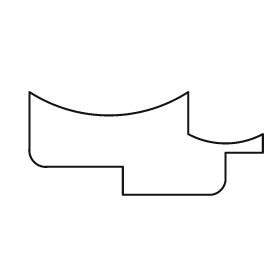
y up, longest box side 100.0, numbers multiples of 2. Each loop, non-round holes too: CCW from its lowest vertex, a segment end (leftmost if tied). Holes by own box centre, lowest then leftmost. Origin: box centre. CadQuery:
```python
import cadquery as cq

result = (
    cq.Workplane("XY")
    .moveTo(-10.0, -22.0)
    .lineTo(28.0, -22.0)
    .threePointArc((32.0, -20.0), (34.0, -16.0))
    .lineTo(34.0, -4.0)
    .lineTo(50.0, -4.0)
    .lineTo(50.0, 4.0)
    .threePointArc((34.0, 0.0), (18.0, 4.0))
    .lineTo(18.0, 22.0)
    .threePointArc((-16.0, 12.0), (-50.0, 22.0))
    .lineTo(-50.0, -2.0)
    .threePointArc((-48.0, -8.0), (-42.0, -10.0))
    .lineTo(-10.0, -10.0)
    .close()
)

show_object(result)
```